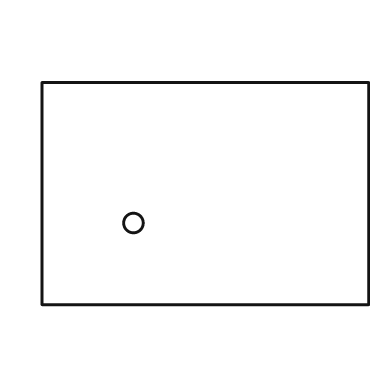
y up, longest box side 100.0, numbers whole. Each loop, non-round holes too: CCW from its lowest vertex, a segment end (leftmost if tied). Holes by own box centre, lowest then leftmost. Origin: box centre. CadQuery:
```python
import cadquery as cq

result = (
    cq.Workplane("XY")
    .moveTo(-50.0, -34.0)
    .lineTo(50.0, -34.0)
    .lineTo(50.0, 34.0)
    .lineTo(-50.0, 34.0)
    .close()
    .moveTo(-22.0, -9.0)
    .circle(3.0)
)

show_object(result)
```